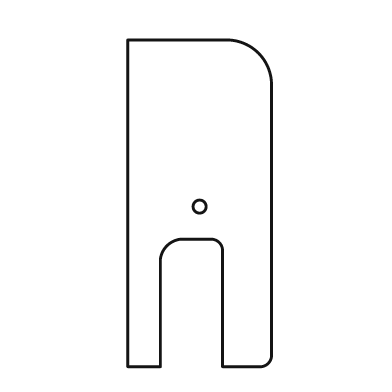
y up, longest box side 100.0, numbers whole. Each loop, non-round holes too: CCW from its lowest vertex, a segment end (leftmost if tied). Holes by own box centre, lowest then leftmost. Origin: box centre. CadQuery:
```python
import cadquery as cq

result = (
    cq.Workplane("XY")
    .moveTo(-22.0, -50.0)
    .lineTo(-12.0, -50.0)
    .lineTo(-12.0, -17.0)
    .threePointArc((-10.0, -13.0), (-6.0, -11.0))
    .lineTo(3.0, -11.0)
    .threePointArc((6.0, -12.0), (7.0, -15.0))
    .lineTo(7.0, -50.0)
    .lineTo(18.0, -50.0)
    .threePointArc((21.0, -49.0), (22.0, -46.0))
    .lineTo(22.0, 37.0)
    .threePointArc((18.0, 46.0), (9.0, 50.0))
    .lineTo(-22.0, 50.0)
    .close()
    .moveTo(0.0, -1.0)
    .circle(2.0)
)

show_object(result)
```